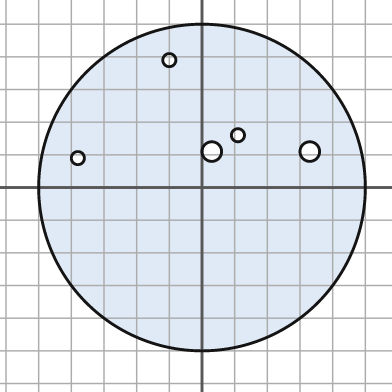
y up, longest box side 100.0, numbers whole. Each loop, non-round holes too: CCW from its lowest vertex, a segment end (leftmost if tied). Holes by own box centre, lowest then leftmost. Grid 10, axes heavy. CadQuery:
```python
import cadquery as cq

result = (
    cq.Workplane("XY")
    .moveTo(0.0, 0.0)
    .circle(50.0)
    .moveTo(-38.0, 9.0)
    .circle(2.0)
    .moveTo(3.0, 11.0)
    .circle(3.0)
    .moveTo(33.0, 11.0)
    .circle(3.0)
    .moveTo(11.0, 16.0)
    .circle(2.0)
    .moveTo(-10.0, 39.0)
    .circle(2.0)
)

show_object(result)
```